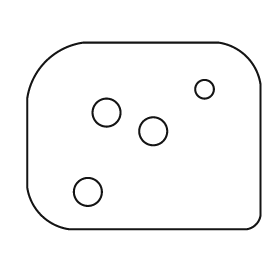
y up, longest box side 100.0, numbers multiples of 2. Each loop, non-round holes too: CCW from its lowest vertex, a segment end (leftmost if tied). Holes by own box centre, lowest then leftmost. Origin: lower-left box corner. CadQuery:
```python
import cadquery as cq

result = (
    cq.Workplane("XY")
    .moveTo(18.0, 0.0)
    .lineTo(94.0, 0.0)
    .threePointArc((98.0, 2.0), (100.0, 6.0))
    .lineTo(100.0, 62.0)
    .threePointArc((94.0, 74.0), (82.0, 80.0))
    .lineTo(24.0, 80.0)
    .threePointArc((8.0, 72.0), (0.0, 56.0))
    .lineTo(0.0, 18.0)
    .threePointArc((6.0, 6.0), (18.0, 0.0))
    .close()
    .moveTo(26.0, 16.0)
    .circle(6.0)
    .moveTo(54.0, 42.0)
    .circle(6.0)
    .moveTo(34.0, 50.0)
    .circle(6.0)
    .moveTo(76.0, 60.0)
    .circle(4.0)
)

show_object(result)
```